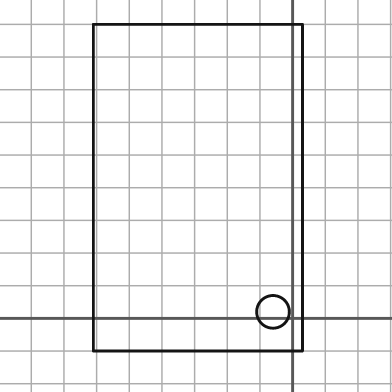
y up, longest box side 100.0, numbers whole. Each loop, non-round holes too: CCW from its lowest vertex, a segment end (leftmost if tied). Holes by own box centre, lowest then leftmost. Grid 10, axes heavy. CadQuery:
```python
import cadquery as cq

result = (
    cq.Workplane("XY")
    .moveTo(-61.0, -10.0)
    .lineTo(3.0, -10.0)
    .lineTo(3.0, 90.0)
    .lineTo(-61.0, 90.0)
    .close()
    .moveTo(-6.0, 2.0)
    .circle(5.0)
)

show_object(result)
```